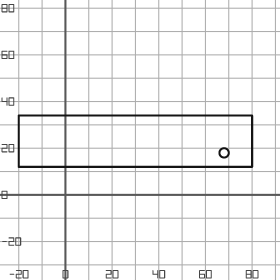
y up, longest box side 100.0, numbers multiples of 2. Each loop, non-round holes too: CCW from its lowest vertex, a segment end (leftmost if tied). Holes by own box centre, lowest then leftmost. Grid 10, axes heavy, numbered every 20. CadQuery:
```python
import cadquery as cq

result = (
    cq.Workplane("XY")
    .moveTo(-20.0, 12.0)
    .lineTo(80.0, 12.0)
    .lineTo(80.0, 34.0)
    .lineTo(-20.0, 34.0)
    .close()
    .moveTo(68.0, 18.0)
    .circle(2.0)
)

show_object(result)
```